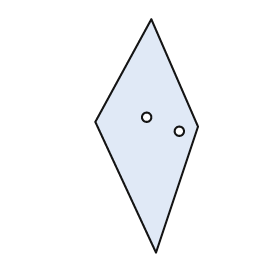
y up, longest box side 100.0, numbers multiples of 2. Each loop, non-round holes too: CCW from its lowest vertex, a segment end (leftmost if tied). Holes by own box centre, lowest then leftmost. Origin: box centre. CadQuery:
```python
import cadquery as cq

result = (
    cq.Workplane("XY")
    .moveTo(4.0, -50.0)
    .lineTo(22.0, 4.0)
    .lineTo(2.0, 50.0)
    .lineTo(-22.0, 6.0)
    .close()
    .moveTo(14.0, 2.0)
    .circle(2.0)
    .moveTo(0.0, 8.0)
    .circle(2.0)
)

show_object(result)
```